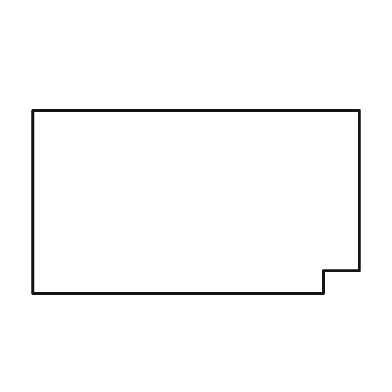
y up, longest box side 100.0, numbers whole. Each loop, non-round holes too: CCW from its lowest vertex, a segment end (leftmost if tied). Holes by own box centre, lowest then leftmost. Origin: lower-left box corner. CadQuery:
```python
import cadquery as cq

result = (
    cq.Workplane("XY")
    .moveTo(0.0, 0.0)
    .lineTo(89.0, 0.0)
    .lineTo(89.0, 7.0)
    .lineTo(100.0, 7.0)
    .lineTo(100.0, 56.0)
    .lineTo(0.0, 56.0)
    .close()
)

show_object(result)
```